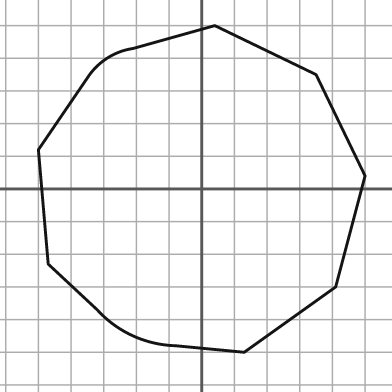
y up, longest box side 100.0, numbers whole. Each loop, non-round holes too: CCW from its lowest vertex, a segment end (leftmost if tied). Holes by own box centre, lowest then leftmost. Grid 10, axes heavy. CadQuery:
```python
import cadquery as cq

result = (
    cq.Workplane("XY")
    .moveTo(13.0, -50.0)
    .lineTo(41.0, -30.0)
    .lineTo(50.0, 4.0)
    .lineTo(35.0, 35.0)
    .lineTo(4.0, 50.0)
    .lineTo(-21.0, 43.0)
    .threePointArc((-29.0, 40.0), (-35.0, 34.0))
    .lineTo(-50.0, 12.0)
    .lineTo(-47.0, -23.0)
    .lineTo(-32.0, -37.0)
    .threePointArc((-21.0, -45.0), (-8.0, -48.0))
    .close()
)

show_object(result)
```